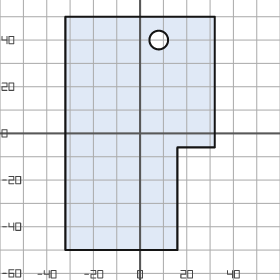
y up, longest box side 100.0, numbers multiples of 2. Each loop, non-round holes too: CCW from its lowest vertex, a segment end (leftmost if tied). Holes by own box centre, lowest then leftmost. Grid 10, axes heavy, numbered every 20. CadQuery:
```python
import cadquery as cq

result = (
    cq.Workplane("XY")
    .moveTo(-32.0, -50.0)
    .lineTo(16.0, -50.0)
    .lineTo(16.0, -6.0)
    .lineTo(32.0, -6.0)
    .lineTo(32.0, 50.0)
    .lineTo(-32.0, 50.0)
    .close()
    .moveTo(8.0, 40.0)
    .circle(4.0)
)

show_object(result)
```